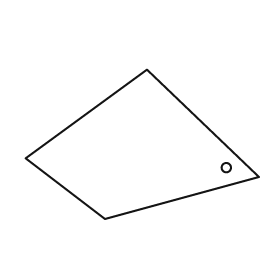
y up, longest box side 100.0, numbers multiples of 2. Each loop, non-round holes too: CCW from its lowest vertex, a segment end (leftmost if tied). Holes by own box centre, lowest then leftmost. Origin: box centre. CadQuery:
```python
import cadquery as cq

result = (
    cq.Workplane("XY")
    .moveTo(-16.0, -32.0)
    .lineTo(50.0, -14.0)
    .lineTo(2.0, 32.0)
    .lineTo(-50.0, -6.0)
    .close()
    .moveTo(36.0, -10.0)
    .circle(2.0)
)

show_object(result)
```